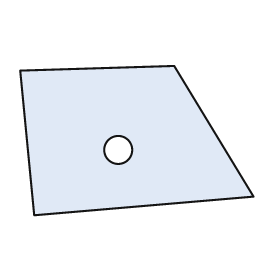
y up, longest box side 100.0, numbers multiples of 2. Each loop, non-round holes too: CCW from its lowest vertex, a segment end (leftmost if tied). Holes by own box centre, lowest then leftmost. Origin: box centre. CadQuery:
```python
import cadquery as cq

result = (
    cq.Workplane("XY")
    .moveTo(-44.0, -32.0)
    .lineTo(50.0, -24.0)
    .lineTo(16.0, 32.0)
    .lineTo(-50.0, 30.0)
    .close()
    .moveTo(-8.0, -4.0)
    .circle(6.0)
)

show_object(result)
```